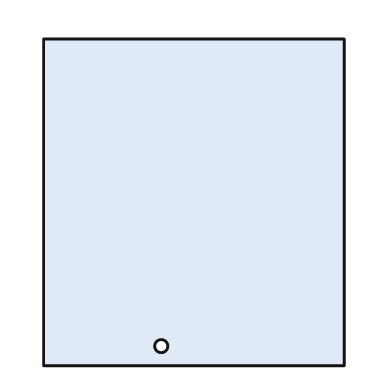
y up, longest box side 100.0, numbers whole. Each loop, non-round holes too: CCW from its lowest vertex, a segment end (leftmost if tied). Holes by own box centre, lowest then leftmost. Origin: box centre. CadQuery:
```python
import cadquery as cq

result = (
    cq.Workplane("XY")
    .moveTo(-46.0, -50.0)
    .lineTo(46.0, -50.0)
    .lineTo(46.0, 50.0)
    .lineTo(-46.0, 50.0)
    .close()
    .moveTo(-10.0, -44.0)
    .circle(2.0)
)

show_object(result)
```